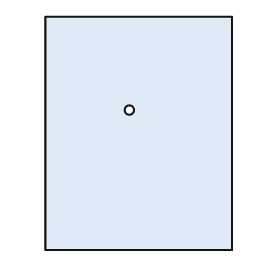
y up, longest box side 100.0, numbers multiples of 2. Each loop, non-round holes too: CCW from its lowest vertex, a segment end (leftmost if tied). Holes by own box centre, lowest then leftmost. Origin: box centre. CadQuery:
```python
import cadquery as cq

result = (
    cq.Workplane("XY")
    .moveTo(-40.0, -50.0)
    .lineTo(40.0, -50.0)
    .lineTo(40.0, 50.0)
    .lineTo(-40.0, 50.0)
    .close()
    .moveTo(-4.0, 10.0)
    .circle(2.0)
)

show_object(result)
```